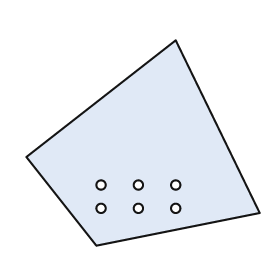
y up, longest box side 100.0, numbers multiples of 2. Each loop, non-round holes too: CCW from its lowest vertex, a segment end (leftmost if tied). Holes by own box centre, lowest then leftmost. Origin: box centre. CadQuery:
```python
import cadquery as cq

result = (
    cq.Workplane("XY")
    .moveTo(-20.0, -44.0)
    .lineTo(50.0, -30.0)
    .lineTo(14.0, 44.0)
    .lineTo(-50.0, -6.0)
    .close()
    .moveTo(-18.0, -28.0)
    .circle(2.0)
    .moveTo(-2.0, -28.0)
    .circle(2.0)
    .moveTo(14.0, -28.0)
    .circle(2.0)
    .moveTo(-18.0, -18.0)
    .circle(2.0)
    .moveTo(-2.0, -18.0)
    .circle(2.0)
    .moveTo(14.0, -18.0)
    .circle(2.0)
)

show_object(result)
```